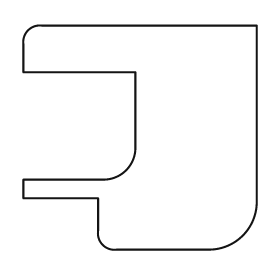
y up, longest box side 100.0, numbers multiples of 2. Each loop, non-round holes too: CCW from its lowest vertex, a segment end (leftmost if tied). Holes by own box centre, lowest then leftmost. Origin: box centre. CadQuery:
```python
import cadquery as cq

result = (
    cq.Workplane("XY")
    .moveTo(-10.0, -48.0)
    .lineTo(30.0, -48.0)
    .threePointArc((44.0, -42.0), (50.0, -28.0))
    .lineTo(50.0, 48.0)
    .lineTo(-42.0, 48.0)
    .threePointArc((-48.0, 46.0), (-50.0, 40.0))
    .lineTo(-50.0, 28.0)
    .lineTo(-2.0, 28.0)
    .lineTo(-2.0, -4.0)
    .threePointArc((-6.0, -14.0), (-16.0, -18.0))
    .lineTo(-50.0, -18.0)
    .lineTo(-50.0, -26.0)
    .lineTo(-18.0, -26.0)
    .lineTo(-18.0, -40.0)
    .threePointArc((-16.0, -46.0), (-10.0, -48.0))
    .close()
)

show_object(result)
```